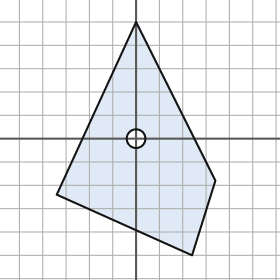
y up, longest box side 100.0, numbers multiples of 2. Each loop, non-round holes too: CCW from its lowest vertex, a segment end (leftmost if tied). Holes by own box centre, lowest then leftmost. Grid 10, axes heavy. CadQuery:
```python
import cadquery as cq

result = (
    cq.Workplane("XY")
    .moveTo(24.0, -50.0)
    .lineTo(34.0, -18.0)
    .lineTo(0.0, 50.0)
    .lineTo(-34.0, -24.0)
    .close()
    .moveTo(0.0, 0.0)
    .circle(4.0)
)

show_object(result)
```